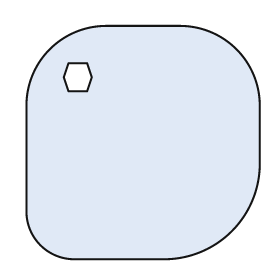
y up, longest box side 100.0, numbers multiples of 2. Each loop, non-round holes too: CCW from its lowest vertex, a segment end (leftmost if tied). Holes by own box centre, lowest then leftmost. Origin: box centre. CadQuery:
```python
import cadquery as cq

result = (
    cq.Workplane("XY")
    .moveTo(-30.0, -50.0)
    .lineTo(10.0, -50.0)
    .threePointArc((38.0, -38.0), (50.0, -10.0))
    .lineTo(50.0, 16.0)
    .threePointArc((40.0, 40.0), (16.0, 50.0))
    .lineTo(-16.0, 50.0)
    .threePointArc((-40.0, 40.0), (-50.0, 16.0))
    .lineTo(-50.0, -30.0)
    .threePointArc((-44.0, -44.0), (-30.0, -50.0))
    .close()
    .moveTo(-32.0, 22.0)
    .lineTo(-24.0, 22.0)
    .lineTo(-22.0, 28.0)
    .lineTo(-24.0, 34.0)
    .lineTo(-32.0, 34.0)
    .lineTo(-34.0, 28.0)
    .close()
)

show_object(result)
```